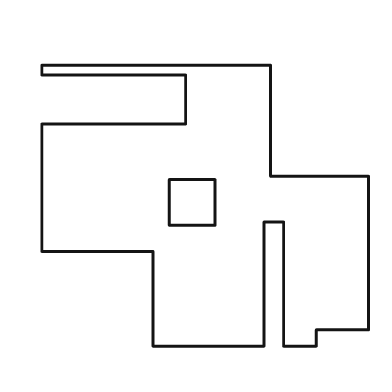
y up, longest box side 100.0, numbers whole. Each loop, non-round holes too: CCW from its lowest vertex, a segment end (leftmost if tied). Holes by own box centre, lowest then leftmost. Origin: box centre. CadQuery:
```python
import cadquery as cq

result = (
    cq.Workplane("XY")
    .moveTo(-16.0, -43.0)
    .lineTo(18.0, -43.0)
    .lineTo(18.0, -5.0)
    .lineTo(24.0, -5.0)
    .lineTo(24.0, -43.0)
    .lineTo(34.0, -43.0)
    .lineTo(34.0, -38.0)
    .lineTo(50.0, -38.0)
    .lineTo(50.0, 9.0)
    .lineTo(20.0, 9.0)
    .lineTo(20.0, 43.0)
    .lineTo(-50.0, 43.0)
    .lineTo(-50.0, 40.0)
    .lineTo(-6.0, 40.0)
    .lineTo(-6.0, 25.0)
    .lineTo(-50.0, 25.0)
    .lineTo(-50.0, -14.0)
    .lineTo(-16.0, -14.0)
    .close()
    .moveTo(-11.0, -6.0)
    .lineTo(3.0, -6.0)
    .lineTo(3.0, 8.0)
    .lineTo(-11.0, 8.0)
    .close()
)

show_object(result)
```